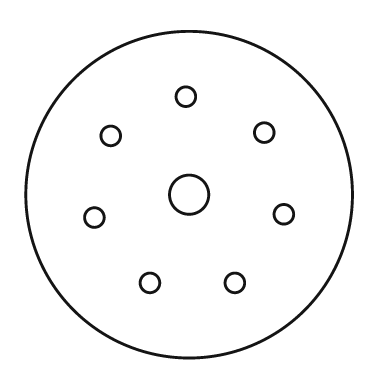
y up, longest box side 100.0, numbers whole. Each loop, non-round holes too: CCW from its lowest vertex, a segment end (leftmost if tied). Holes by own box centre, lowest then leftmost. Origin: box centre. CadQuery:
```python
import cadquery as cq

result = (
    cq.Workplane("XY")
    .moveTo(0.0, 0.0)
    .circle(50.0)
    .moveTo(-12.0, -27.0)
    .circle(3.0)
    .moveTo(14.0, -27.0)
    .circle(3.0)
    .moveTo(-29.0, -7.0)
    .circle(3.0)
    .moveTo(29.0, -6.0)
    .circle(3.0)
    .moveTo(0.0, 0.0)
    .circle(6.0)
    .moveTo(-24.0, 18.0)
    .circle(3.0)
    .moveTo(23.0, 19.0)
    .circle(3.0)
    .moveTo(-1.0, 30.0)
    .circle(3.0)
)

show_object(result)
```